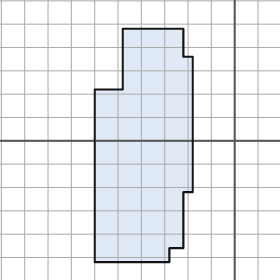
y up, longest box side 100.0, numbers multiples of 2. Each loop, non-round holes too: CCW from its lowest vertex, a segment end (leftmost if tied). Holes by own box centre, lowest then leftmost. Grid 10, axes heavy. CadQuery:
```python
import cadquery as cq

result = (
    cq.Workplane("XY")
    .moveTo(-60.0, -52.0)
    .lineTo(-28.0, -52.0)
    .lineTo(-28.0, -46.0)
    .lineTo(-22.0, -46.0)
    .lineTo(-22.0, -22.0)
    .lineTo(-18.0, -22.0)
    .lineTo(-18.0, 36.0)
    .lineTo(-22.0, 36.0)
    .lineTo(-22.0, 48.0)
    .lineTo(-48.0, 48.0)
    .lineTo(-48.0, 22.0)
    .lineTo(-60.0, 22.0)
    .close()
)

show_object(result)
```